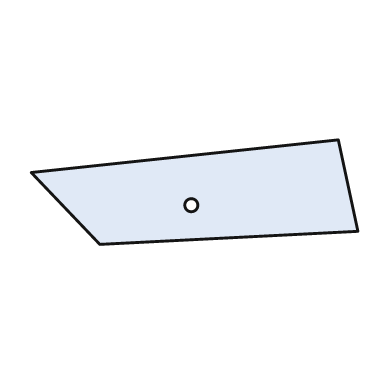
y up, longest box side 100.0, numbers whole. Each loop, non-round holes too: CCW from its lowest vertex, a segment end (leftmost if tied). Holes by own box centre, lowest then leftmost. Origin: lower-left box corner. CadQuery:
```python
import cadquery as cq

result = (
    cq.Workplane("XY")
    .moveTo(21.0, 0.0)
    .lineTo(100.0, 4.0)
    .lineTo(94.0, 32.0)
    .lineTo(0.0, 22.0)
    .close()
    .moveTo(49.0, 12.0)
    .circle(2.0)
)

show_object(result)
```